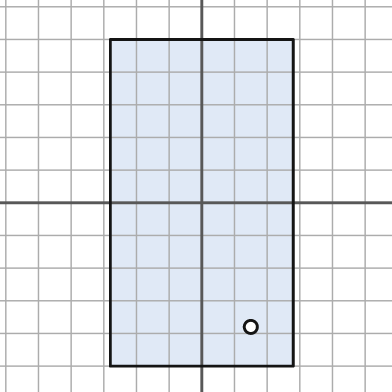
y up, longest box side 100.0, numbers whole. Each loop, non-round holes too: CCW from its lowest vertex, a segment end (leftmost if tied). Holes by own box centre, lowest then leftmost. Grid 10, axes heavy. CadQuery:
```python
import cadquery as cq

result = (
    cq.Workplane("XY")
    .moveTo(-28.0, -50.0)
    .lineTo(28.0, -50.0)
    .lineTo(28.0, 50.0)
    .lineTo(-28.0, 50.0)
    .close()
    .moveTo(15.0, -38.0)
    .circle(2.0)
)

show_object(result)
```